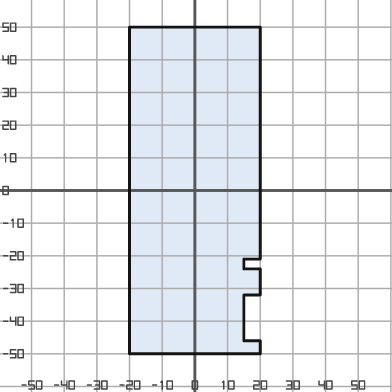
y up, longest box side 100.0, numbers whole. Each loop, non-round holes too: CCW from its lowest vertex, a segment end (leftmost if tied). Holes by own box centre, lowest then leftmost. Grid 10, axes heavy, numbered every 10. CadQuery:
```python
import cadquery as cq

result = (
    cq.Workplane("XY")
    .moveTo(-20.0, -50.0)
    .lineTo(20.0, -50.0)
    .lineTo(20.0, -46.0)
    .lineTo(15.0, -46.0)
    .lineTo(15.0, -32.0)
    .lineTo(20.0, -32.0)
    .lineTo(20.0, -24.0)
    .lineTo(15.0, -24.0)
    .lineTo(15.0, -21.0)
    .lineTo(20.0, -21.0)
    .lineTo(20.0, 50.0)
    .lineTo(-20.0, 50.0)
    .close()
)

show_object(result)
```